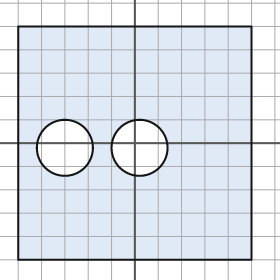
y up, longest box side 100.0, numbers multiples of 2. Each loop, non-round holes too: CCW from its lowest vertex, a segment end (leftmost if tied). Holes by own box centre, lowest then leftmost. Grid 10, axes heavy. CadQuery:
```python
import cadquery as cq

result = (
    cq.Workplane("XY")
    .moveTo(-50.0, -50.0)
    .lineTo(50.0, -50.0)
    .lineTo(50.0, 50.0)
    .lineTo(-50.0, 50.0)
    .close()
    .moveTo(-30.0, -2.0)
    .circle(12.0)
    .moveTo(2.0, -2.0)
    .circle(12.0)
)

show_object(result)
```